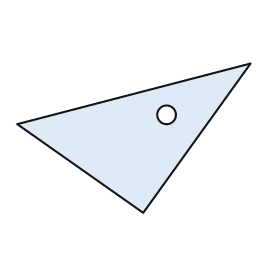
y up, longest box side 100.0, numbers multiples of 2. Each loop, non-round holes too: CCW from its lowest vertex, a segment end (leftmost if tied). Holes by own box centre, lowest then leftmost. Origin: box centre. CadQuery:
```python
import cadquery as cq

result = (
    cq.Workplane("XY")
    .moveTo(4.0, -32.0)
    .lineTo(50.0, 32.0)
    .lineTo(-50.0, 6.0)
    .close()
    .moveTo(14.0, 10.0)
    .circle(4.0)
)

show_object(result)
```